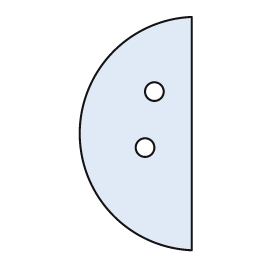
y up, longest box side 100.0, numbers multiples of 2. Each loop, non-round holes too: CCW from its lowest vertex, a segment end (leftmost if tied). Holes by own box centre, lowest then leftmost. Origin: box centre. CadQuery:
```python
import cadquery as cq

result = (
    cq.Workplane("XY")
    .moveTo(24.0, -50.0)
    .lineTo(24.0, 50.0)
    .threePointArc((-24.0, 0.0), (24.0, -50.0))
    .close()
    .moveTo(4.0, -6.0)
    .circle(4.0)
    .moveTo(8.0, 18.0)
    .circle(4.0)
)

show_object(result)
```